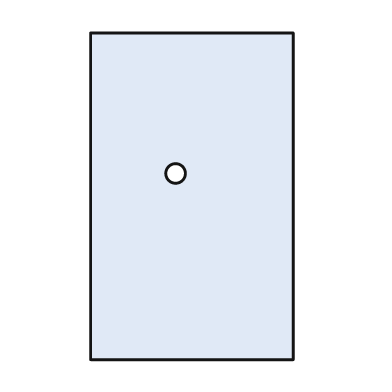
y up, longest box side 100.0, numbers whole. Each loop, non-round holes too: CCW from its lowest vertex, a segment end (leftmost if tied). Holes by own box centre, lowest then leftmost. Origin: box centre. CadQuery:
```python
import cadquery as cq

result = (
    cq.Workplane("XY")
    .moveTo(-31.0, -50.0)
    .lineTo(31.0, -50.0)
    .lineTo(31.0, 50.0)
    .lineTo(-31.0, 50.0)
    .close()
    .moveTo(-5.0, 7.0)
    .circle(3.0)
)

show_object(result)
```